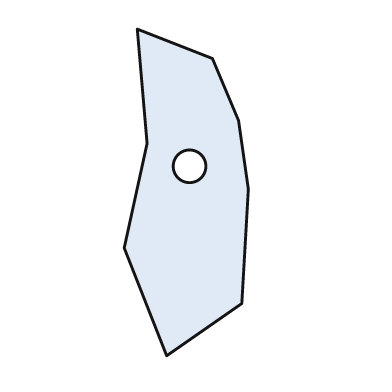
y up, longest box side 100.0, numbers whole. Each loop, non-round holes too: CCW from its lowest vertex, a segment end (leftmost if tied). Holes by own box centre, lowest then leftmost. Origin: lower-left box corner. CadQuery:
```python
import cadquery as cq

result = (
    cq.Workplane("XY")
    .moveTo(13.0, 0.0)
    .lineTo(36.0, 16.0)
    .lineTo(38.0, 51.0)
    .lineTo(35.0, 72.0)
    .lineTo(27.0, 91.0)
    .lineTo(4.0, 100.0)
    .lineTo(7.0, 65.0)
    .lineTo(0.0, 33.0)
    .close()
    .moveTo(20.0, 58.0)
    .circle(5.0)
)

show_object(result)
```